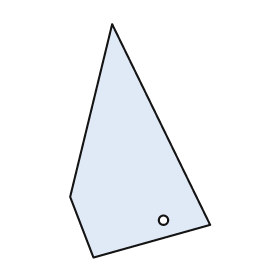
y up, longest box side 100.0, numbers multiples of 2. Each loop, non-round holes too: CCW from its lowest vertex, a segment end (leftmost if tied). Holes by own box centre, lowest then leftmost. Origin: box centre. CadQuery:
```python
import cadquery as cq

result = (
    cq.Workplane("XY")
    .moveTo(-20.0, -50.0)
    .lineTo(30.0, -36.0)
    .lineTo(-12.0, 50.0)
    .lineTo(-30.0, -24.0)
    .close()
    .moveTo(10.0, -34.0)
    .circle(2.0)
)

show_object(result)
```